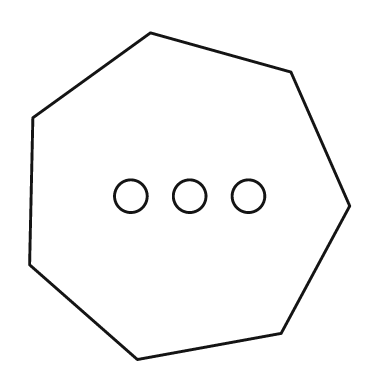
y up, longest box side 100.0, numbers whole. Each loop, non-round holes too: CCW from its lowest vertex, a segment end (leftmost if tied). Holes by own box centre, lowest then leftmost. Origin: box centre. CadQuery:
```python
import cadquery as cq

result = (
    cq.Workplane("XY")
    .moveTo(-16.0, -50.0)
    .lineTo(28.0, -42.0)
    .lineTo(49.0, -3.0)
    .lineTo(31.0, 38.0)
    .lineTo(-12.0, 50.0)
    .lineTo(-48.0, 24.0)
    .lineTo(-49.0, -21.0)
    .close()
    .moveTo(-18.0, 0.0)
    .circle(5.0)
    .moveTo(0.0, 0.0)
    .circle(5.0)
    .moveTo(18.0, 0.0)
    .circle(5.0)
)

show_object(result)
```